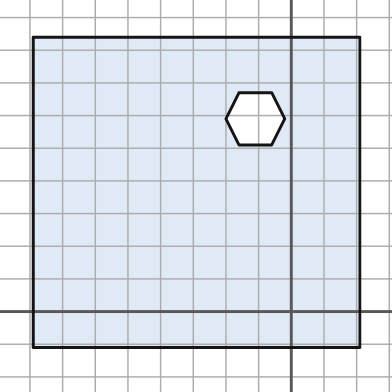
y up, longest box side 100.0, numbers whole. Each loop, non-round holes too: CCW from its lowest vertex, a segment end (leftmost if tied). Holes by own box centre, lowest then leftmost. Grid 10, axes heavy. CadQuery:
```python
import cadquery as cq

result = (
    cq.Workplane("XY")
    .moveTo(-79.0, -11.0)
    .lineTo(21.0, -11.0)
    .lineTo(21.0, 84.0)
    .lineTo(-79.0, 84.0)
    .close()
    .moveTo(-16.0, 51.0)
    .lineTo(-6.0, 51.0)
    .lineTo(-2.0, 59.0)
    .lineTo(-6.0, 67.0)
    .lineTo(-16.0, 67.0)
    .lineTo(-20.0, 59.0)
    .close()
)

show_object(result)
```